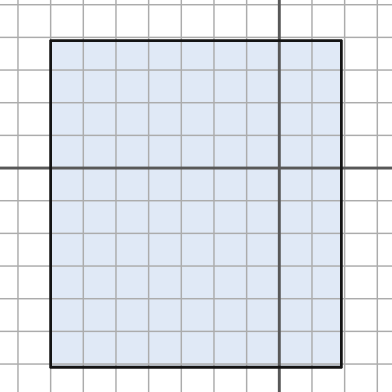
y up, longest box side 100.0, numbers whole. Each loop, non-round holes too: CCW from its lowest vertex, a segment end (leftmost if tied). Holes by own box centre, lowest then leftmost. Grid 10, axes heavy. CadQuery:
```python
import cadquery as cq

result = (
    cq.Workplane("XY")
    .moveTo(-70.0, -61.0)
    .lineTo(19.0, -61.0)
    .lineTo(19.0, 39.0)
    .lineTo(-70.0, 39.0)
    .close()
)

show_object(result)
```